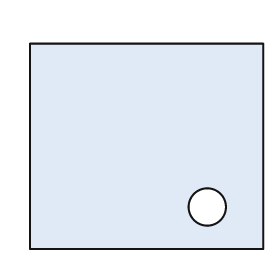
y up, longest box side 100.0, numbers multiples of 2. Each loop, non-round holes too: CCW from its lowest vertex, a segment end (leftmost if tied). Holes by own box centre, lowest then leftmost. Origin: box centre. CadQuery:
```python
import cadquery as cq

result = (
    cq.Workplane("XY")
    .moveTo(-50.0, -44.0)
    .lineTo(50.0, -44.0)
    .lineTo(50.0, 44.0)
    .lineTo(-50.0, 44.0)
    .close()
    .moveTo(26.0, -26.0)
    .circle(8.0)
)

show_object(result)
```